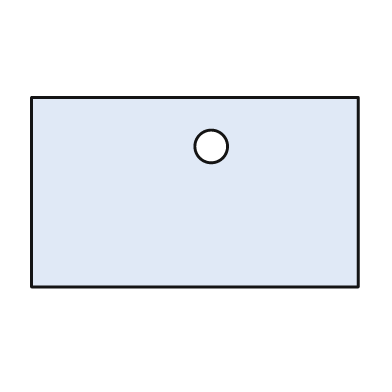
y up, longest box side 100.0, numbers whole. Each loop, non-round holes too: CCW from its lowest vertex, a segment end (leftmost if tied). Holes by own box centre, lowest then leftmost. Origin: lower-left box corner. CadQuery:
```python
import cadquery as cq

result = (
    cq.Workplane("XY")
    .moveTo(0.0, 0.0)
    .lineTo(100.0, 0.0)
    .lineTo(100.0, 58.0)
    .lineTo(0.0, 58.0)
    .close()
    .moveTo(55.0, 43.0)
    .circle(5.0)
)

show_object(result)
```